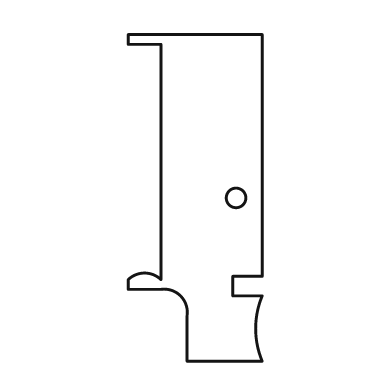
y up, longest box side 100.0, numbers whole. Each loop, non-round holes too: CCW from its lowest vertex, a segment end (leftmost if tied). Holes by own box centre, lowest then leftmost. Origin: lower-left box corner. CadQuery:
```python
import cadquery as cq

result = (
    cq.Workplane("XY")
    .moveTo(18.0, 0.0)
    .lineTo(41.0, 0.0)
    .threePointArc((39.0, 10.0), (41.0, 20.0))
    .lineTo(32.0, 20.0)
    .lineTo(32.0, 26.0)
    .lineTo(41.0, 26.0)
    .lineTo(41.0, 100.0)
    .lineTo(0.0, 100.0)
    .lineTo(0.0, 97.0)
    .lineTo(10.0, 97.0)
    .lineTo(10.0, 25.0)
    .threePointArc((5.0, 27.0), (0.0, 25.0))
    .lineTo(0.0, 22.0)
    .lineTo(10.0, 22.0)
    .threePointArc((16.0, 20.0), (18.0, 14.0))
    .close()
    .moveTo(33.0, 50.0)
    .circle(3.0)
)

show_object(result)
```